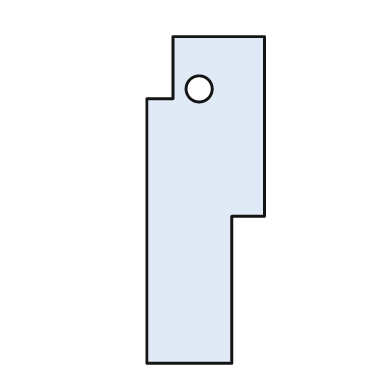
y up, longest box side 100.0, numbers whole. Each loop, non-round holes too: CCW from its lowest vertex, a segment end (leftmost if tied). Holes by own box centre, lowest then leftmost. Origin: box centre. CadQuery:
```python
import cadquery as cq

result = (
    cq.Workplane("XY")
    .moveTo(-18.0, -50.0)
    .lineTo(8.0, -50.0)
    .lineTo(8.0, -5.0)
    .lineTo(18.0, -5.0)
    .lineTo(18.0, 50.0)
    .lineTo(-10.0, 50.0)
    .lineTo(-10.0, 31.0)
    .lineTo(-18.0, 31.0)
    .close()
    .moveTo(-2.0, 34.0)
    .circle(4.0)
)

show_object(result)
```